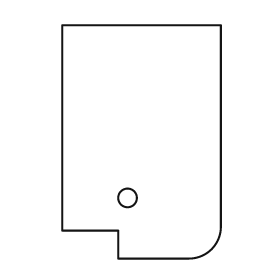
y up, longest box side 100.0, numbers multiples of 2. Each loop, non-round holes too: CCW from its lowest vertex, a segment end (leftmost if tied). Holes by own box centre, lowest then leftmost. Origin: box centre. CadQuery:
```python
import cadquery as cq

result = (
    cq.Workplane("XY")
    .moveTo(-10.0, -50.0)
    .lineTo(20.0, -50.0)
    .threePointArc((30.0, -46.0), (34.0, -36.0))
    .lineTo(34.0, 50.0)
    .lineTo(-34.0, 50.0)
    .lineTo(-34.0, -38.0)
    .lineTo(-10.0, -38.0)
    .close()
    .moveTo(-6.0, -24.0)
    .circle(4.0)
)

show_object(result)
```